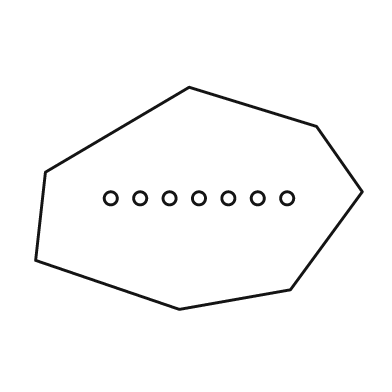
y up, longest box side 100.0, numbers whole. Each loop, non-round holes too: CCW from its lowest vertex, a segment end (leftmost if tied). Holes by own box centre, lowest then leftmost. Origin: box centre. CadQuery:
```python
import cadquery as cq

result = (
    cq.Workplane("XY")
    .moveTo(-6.0, -34.0)
    .lineTo(28.0, -28.0)
    .lineTo(50.0, 2.0)
    .lineTo(36.0, 22.0)
    .lineTo(-3.0, 34.0)
    .lineTo(-47.0, 8.0)
    .lineTo(-50.0, -19.0)
    .close()
    .moveTo(-27.0, 0.0)
    .circle(2.0)
    .moveTo(-18.0, 0.0)
    .circle(2.0)
    .moveTo(-9.0, 0.0)
    .circle(2.0)
    .moveTo(0.0, 0.0)
    .circle(2.0)
    .moveTo(9.0, 0.0)
    .circle(2.0)
    .moveTo(18.0, 0.0)
    .circle(2.0)
    .moveTo(27.0, 0.0)
    .circle(2.0)
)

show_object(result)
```